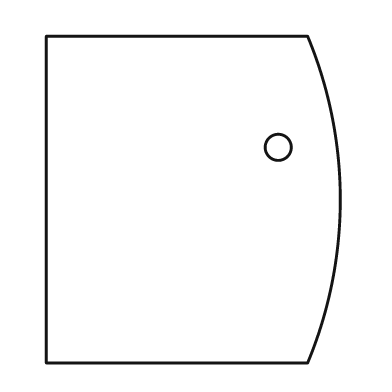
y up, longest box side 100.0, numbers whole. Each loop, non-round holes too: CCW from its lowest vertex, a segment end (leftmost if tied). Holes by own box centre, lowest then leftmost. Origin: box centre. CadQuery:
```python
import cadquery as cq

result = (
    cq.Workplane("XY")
    .moveTo(-45.0, -50.0)
    .lineTo(35.0, -50.0)
    .threePointArc((45.0, 0.0), (35.0, 50.0))
    .lineTo(-45.0, 50.0)
    .close()
    .moveTo(26.0, 16.0)
    .circle(4.0)
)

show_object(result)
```